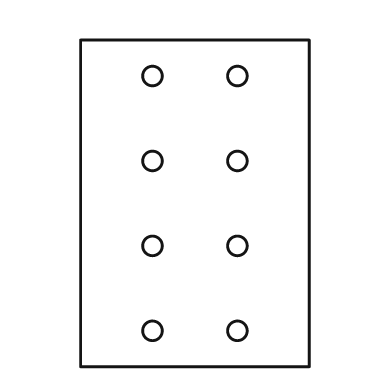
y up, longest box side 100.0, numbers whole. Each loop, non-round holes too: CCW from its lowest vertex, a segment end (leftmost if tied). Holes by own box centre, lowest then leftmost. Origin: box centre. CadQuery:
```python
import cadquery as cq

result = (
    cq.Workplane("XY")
    .moveTo(-35.0, -50.0)
    .lineTo(35.0, -50.0)
    .lineTo(35.0, 50.0)
    .lineTo(-35.0, 50.0)
    .close()
    .moveTo(-13.0, -39.0)
    .circle(3.0)
    .moveTo(13.0, -39.0)
    .circle(3.0)
    .moveTo(-13.0, -13.0)
    .circle(3.0)
    .moveTo(13.0, -13.0)
    .circle(3.0)
    .moveTo(-13.0, 13.0)
    .circle(3.0)
    .moveTo(13.0, 13.0)
    .circle(3.0)
    .moveTo(-13.0, 39.0)
    .circle(3.0)
    .moveTo(13.0, 39.0)
    .circle(3.0)
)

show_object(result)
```